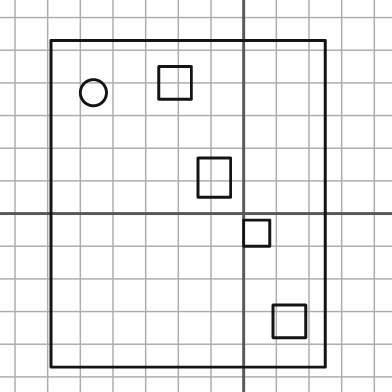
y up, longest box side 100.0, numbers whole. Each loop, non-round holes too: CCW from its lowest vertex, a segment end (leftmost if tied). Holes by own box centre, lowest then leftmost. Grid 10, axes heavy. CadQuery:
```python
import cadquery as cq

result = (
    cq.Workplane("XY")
    .moveTo(-59.0, -47.0)
    .lineTo(25.0, -47.0)
    .lineTo(25.0, 53.0)
    .lineTo(-59.0, 53.0)
    .close()
    .moveTo(9.0, -38.0)
    .lineTo(19.0, -38.0)
    .lineTo(19.0, -28.0)
    .lineTo(9.0, -28.0)
    .close()
    .moveTo(0.0, -10.0)
    .lineTo(8.0, -10.0)
    .lineTo(8.0, -2.0)
    .lineTo(0.0, -2.0)
    .close()
    .moveTo(-14.0, 5.0)
    .lineTo(-4.0, 5.0)
    .lineTo(-4.0, 17.0)
    .lineTo(-14.0, 17.0)
    .close()
    .moveTo(-46.0, 37.0)
    .circle(4.0)
    .moveTo(-26.0, 35.0)
    .lineTo(-16.0, 35.0)
    .lineTo(-16.0, 45.0)
    .lineTo(-26.0, 45.0)
    .close()
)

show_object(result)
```